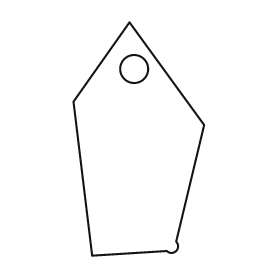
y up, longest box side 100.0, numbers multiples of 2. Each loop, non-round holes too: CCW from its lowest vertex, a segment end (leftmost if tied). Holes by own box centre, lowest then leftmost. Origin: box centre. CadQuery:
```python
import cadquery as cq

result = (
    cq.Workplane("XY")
    .moveTo(-20.0, -50.0)
    .lineTo(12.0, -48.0)
    .threePointArc((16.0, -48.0), (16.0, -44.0))
    .lineTo(28.0, 6.0)
    .lineTo(-4.0, 50.0)
    .lineTo(-28.0, 16.0)
    .close()
    .moveTo(-2.0, 30.0)
    .circle(6.0)
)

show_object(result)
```